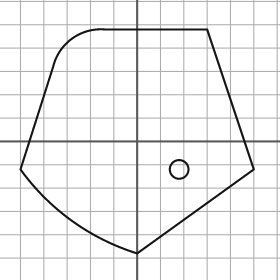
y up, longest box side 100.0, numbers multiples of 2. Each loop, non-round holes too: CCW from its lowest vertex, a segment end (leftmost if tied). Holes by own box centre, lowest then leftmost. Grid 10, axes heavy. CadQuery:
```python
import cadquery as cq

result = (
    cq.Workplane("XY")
    .moveTo(0.0, -48.0)
    .lineTo(50.0, -12.0)
    .lineTo(30.0, 48.0)
    .lineTo(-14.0, 48.0)
    .threePointArc((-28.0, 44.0), (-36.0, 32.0))
    .lineTo(-50.0, -12.0)
    .threePointArc((-28.0, -34.0), (0.0, -48.0))
    .close()
    .moveTo(18.0, -12.0)
    .circle(4.0)
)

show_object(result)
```